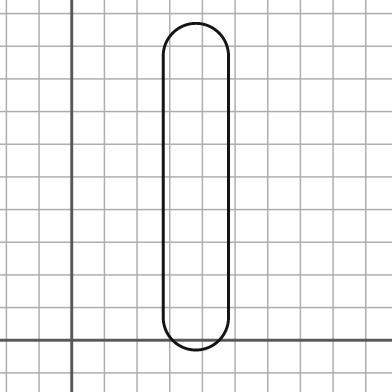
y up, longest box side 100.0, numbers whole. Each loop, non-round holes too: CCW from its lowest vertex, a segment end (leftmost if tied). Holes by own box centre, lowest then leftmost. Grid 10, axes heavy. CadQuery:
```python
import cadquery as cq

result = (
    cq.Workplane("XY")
    .moveTo(28.0, 7.0)
    .threePointArc((38.0, -3.0), (48.0, 7.0))
    .lineTo(48.0, 87.0)
    .threePointArc((38.0, 97.0), (28.0, 87.0))
    .close()
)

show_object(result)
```